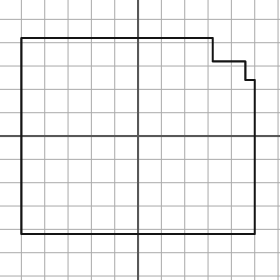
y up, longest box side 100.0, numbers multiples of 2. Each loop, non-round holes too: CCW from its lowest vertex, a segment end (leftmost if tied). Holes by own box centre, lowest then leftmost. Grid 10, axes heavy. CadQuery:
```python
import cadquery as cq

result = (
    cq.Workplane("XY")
    .moveTo(-50.0, -42.0)
    .lineTo(50.0, -42.0)
    .lineTo(50.0, 24.0)
    .lineTo(46.0, 24.0)
    .lineTo(46.0, 32.0)
    .lineTo(32.0, 32.0)
    .lineTo(32.0, 42.0)
    .lineTo(-50.0, 42.0)
    .close()
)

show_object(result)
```